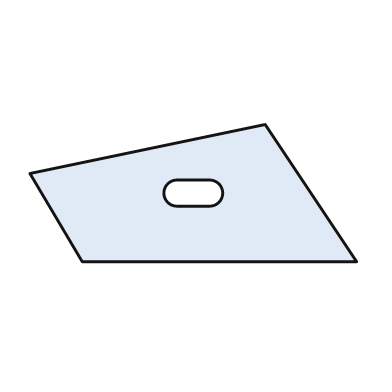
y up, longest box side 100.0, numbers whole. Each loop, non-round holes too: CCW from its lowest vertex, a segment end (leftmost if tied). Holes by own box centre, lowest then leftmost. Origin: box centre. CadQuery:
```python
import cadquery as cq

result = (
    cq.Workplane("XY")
    .moveTo(-34.0, -21.0)
    .lineTo(50.0, -21.0)
    .lineTo(22.0, 21.0)
    .lineTo(-50.0, 6.0)
    .close()
    .moveTo(-5.0, -4.0)
    .lineTo(5.0, -4.0)
    .threePointArc((9.0, 0.0), (5.0, 4.0))
    .lineTo(-5.0, 4.0)
    .threePointArc((-9.0, 0.0), (-5.0, -4.0))
    .close()
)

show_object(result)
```